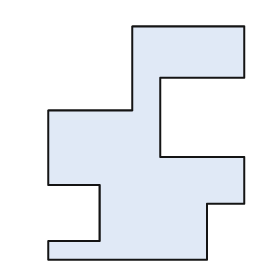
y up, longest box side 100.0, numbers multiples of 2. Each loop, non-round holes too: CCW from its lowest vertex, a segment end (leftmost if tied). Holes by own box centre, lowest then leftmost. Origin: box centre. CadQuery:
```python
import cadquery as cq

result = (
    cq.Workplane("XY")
    .moveTo(-42.0, -50.0)
    .lineTo(26.0, -50.0)
    .lineTo(26.0, -26.0)
    .lineTo(42.0, -26.0)
    .lineTo(42.0, -6.0)
    .lineTo(6.0, -6.0)
    .lineTo(6.0, 28.0)
    .lineTo(42.0, 28.0)
    .lineTo(42.0, 50.0)
    .lineTo(-6.0, 50.0)
    .lineTo(-6.0, 14.0)
    .lineTo(-42.0, 14.0)
    .lineTo(-42.0, -18.0)
    .lineTo(-20.0, -18.0)
    .lineTo(-20.0, -42.0)
    .lineTo(-42.0, -42.0)
    .close()
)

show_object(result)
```